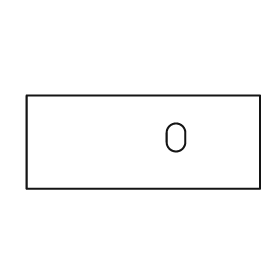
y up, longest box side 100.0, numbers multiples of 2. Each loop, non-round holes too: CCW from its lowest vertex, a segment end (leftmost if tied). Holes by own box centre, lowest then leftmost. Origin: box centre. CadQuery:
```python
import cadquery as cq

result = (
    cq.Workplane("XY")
    .moveTo(-50.0, -20.0)
    .lineTo(50.0, -20.0)
    .lineTo(50.0, 20.0)
    .lineTo(-50.0, 20.0)
    .close()
    .moveTo(10.0, 0.0)
    .threePointArc((14.0, -4.0), (18.0, 0.0))
    .lineTo(18.0, 4.0)
    .threePointArc((14.0, 8.0), (10.0, 4.0))
    .close()
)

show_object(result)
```